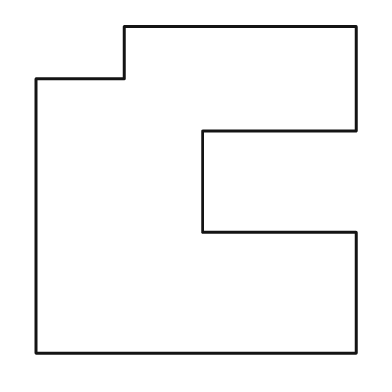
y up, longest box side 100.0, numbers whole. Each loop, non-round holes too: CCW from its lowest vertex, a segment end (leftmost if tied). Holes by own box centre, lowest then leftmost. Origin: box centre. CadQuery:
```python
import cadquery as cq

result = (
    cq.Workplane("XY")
    .moveTo(-49.0, -50.0)
    .lineTo(49.0, -50.0)
    .lineTo(49.0, -13.0)
    .lineTo(2.0, -13.0)
    .lineTo(2.0, 18.0)
    .lineTo(49.0, 18.0)
    .lineTo(49.0, 50.0)
    .lineTo(-22.0, 50.0)
    .lineTo(-22.0, 34.0)
    .lineTo(-49.0, 34.0)
    .close()
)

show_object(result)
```